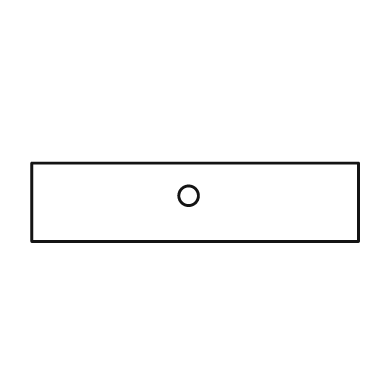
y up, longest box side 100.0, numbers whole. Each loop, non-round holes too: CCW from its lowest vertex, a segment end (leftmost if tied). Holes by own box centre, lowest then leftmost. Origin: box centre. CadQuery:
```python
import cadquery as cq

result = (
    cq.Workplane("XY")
    .moveTo(-50.0, -12.0)
    .lineTo(50.0, -12.0)
    .lineTo(50.0, 12.0)
    .lineTo(-50.0, 12.0)
    .close()
    .moveTo(-2.0, 2.0)
    .circle(3.0)
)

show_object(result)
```